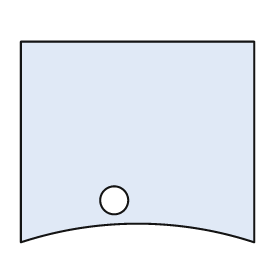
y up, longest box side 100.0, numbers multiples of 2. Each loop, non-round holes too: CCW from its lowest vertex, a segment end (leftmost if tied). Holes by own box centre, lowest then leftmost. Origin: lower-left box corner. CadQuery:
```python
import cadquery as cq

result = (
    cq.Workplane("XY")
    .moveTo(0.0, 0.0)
    .threePointArc((50.0, 8.0), (100.0, 0.0))
    .lineTo(100.0, 86.0)
    .lineTo(0.0, 86.0)
    .close()
    .moveTo(40.0, 18.0)
    .circle(6.0)
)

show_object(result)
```